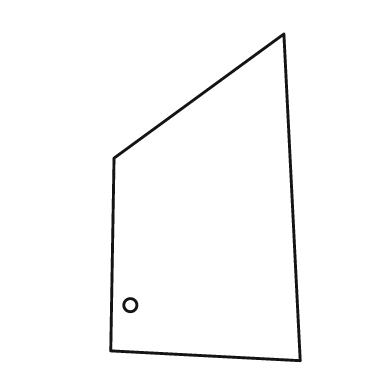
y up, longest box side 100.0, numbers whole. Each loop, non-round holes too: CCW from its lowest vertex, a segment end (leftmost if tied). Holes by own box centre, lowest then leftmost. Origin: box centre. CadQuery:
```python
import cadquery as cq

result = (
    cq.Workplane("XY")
    .moveTo(29.0, -50.0)
    .lineTo(24.0, 50.0)
    .lineTo(-28.0, 12.0)
    .lineTo(-29.0, -47.0)
    .close()
    .moveTo(-23.0, -33.0)
    .circle(2.0)
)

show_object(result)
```